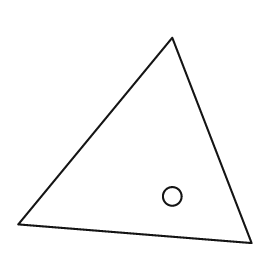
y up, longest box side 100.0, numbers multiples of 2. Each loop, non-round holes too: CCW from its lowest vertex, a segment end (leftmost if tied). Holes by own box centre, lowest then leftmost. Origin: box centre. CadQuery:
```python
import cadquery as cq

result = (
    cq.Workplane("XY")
    .moveTo(50.0, -44.0)
    .lineTo(16.0, 44.0)
    .lineTo(-50.0, -36.0)
    .close()
    .moveTo(16.0, -24.0)
    .circle(4.0)
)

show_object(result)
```